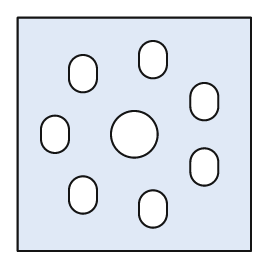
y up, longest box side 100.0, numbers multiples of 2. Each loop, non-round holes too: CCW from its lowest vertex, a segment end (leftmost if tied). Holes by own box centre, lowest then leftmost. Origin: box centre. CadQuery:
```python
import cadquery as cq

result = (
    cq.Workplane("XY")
    .moveTo(-50.0, -50.0)
    .lineTo(50.0, -50.0)
    .lineTo(50.0, 50.0)
    .lineTo(-50.0, 50.0)
    .close()
    .moveTo(2.0, -34.0)
    .threePointArc((8.0, -40.0), (14.0, -34.0))
    .lineTo(14.0, -30.0)
    .threePointArc((8.0, -24.0), (2.0, -30.0))
    .close()
    .moveTo(-28.0, -28.0)
    .threePointArc((-22.0, -34.0), (-16.0, -28.0))
    .lineTo(-16.0, -24.0)
    .threePointArc((-22.0, -18.0), (-28.0, -24.0))
    .close()
    .moveTo(24.0, -16.0)
    .threePointArc((30.0, -22.0), (36.0, -16.0))
    .lineTo(36.0, -12.0)
    .threePointArc((30.0, -6.0), (24.0, -12.0))
    .close()
    .moveTo(-40.0, -2.0)
    .threePointArc((-34.0, -8.0), (-28.0, -2.0))
    .lineTo(-28.0, 2.0)
    .threePointArc((-34.0, 8.0), (-40.0, 2.0))
    .close()
    .moveTo(0.0, 0.0)
    .circle(10.0)
    .moveTo(24.0, 12.0)
    .threePointArc((30.0, 6.0), (36.0, 12.0))
    .lineTo(36.0, 16.0)
    .threePointArc((30.0, 22.0), (24.0, 16.0))
    .close()
    .moveTo(-28.0, 24.0)
    .threePointArc((-22.0, 18.0), (-16.0, 24.0))
    .lineTo(-16.0, 28.0)
    .threePointArc((-22.0, 34.0), (-28.0, 28.0))
    .close()
    .moveTo(2.0, 30.0)
    .threePointArc((8.0, 24.0), (14.0, 30.0))
    .lineTo(14.0, 34.0)
    .threePointArc((8.0, 40.0), (2.0, 34.0))
    .close()
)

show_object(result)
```